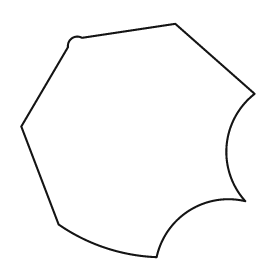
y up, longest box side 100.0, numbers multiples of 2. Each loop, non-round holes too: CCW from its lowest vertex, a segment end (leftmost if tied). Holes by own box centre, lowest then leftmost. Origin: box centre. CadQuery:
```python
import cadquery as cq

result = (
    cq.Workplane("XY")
    .moveTo(8.0, -50.0)
    .threePointArc((22.0, -30.0), (46.0, -26.0))
    .threePointArc((38.0, -2.0), (50.0, 20.0))
    .lineTo(16.0, 50.0)
    .lineTo(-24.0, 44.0)
    .threePointArc((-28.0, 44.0), (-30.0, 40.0))
    .lineTo(-50.0, 6.0)
    .lineTo(-34.0, -36.0)
    .threePointArc((-14.0, -46.0), (8.0, -50.0))
    .close()
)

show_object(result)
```